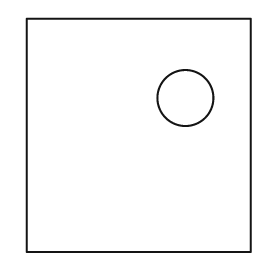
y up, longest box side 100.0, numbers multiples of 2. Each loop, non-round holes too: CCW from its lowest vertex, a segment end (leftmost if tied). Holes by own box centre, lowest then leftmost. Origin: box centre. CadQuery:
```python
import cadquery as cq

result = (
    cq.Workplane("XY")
    .moveTo(-48.0, -50.0)
    .lineTo(48.0, -50.0)
    .lineTo(48.0, 50.0)
    .lineTo(-48.0, 50.0)
    .close()
    .moveTo(20.0, 16.0)
    .circle(12.0)
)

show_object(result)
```